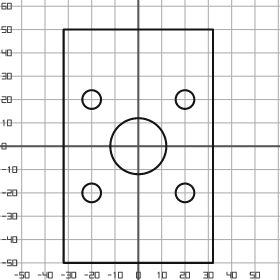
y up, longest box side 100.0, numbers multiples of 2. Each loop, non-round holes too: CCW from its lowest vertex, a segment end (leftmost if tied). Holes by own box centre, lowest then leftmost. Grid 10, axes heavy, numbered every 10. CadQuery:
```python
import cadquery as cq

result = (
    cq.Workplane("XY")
    .moveTo(-32.0, -50.0)
    .lineTo(32.0, -50.0)
    .lineTo(32.0, 50.0)
    .lineTo(-32.0, 50.0)
    .close()
    .moveTo(-20.0, -20.0)
    .circle(4.0)
    .moveTo(20.0, -20.0)
    .circle(4.0)
    .moveTo(0.0, 0.0)
    .circle(12.0)
    .moveTo(-20.0, 20.0)
    .circle(4.0)
    .moveTo(20.0, 20.0)
    .circle(4.0)
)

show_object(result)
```